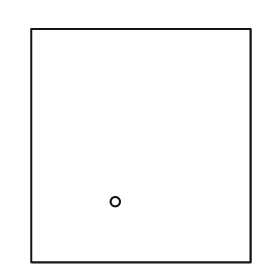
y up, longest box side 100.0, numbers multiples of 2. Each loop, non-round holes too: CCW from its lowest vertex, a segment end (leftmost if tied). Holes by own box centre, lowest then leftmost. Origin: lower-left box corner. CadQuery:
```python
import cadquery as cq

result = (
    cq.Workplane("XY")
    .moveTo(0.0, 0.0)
    .lineTo(94.0, 0.0)
    .lineTo(94.0, 100.0)
    .lineTo(0.0, 100.0)
    .close()
    .moveTo(36.0, 26.0)
    .circle(2.0)
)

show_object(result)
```